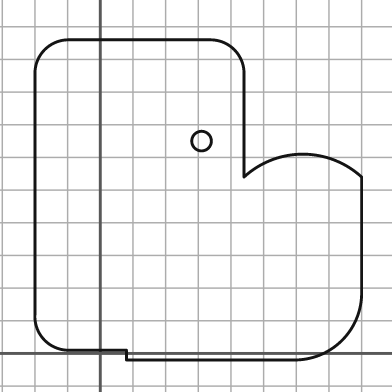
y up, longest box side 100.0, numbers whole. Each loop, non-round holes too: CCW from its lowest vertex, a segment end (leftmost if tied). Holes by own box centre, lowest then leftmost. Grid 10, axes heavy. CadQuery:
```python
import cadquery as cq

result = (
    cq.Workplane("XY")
    .moveTo(8.0, -2.0)
    .lineTo(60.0, -2.0)
    .threePointArc((74.0, 4.0), (80.0, 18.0))
    .lineTo(80.0, 54.0)
    .threePointArc((62.0, 61.0), (44.0, 54.0))
    .lineTo(44.0, 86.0)
    .threePointArc((41.0, 93.0), (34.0, 96.0))
    .lineTo(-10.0, 96.0)
    .threePointArc((-17.0, 93.0), (-20.0, 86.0))
    .lineTo(-20.0, 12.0)
    .threePointArc((-17.0, 4.0), (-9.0, 1.0))
    .lineTo(8.0, 1.0)
    .close()
    .moveTo(31.0, 65.0)
    .circle(3.0)
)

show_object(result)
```